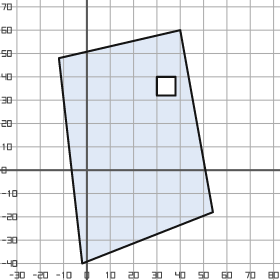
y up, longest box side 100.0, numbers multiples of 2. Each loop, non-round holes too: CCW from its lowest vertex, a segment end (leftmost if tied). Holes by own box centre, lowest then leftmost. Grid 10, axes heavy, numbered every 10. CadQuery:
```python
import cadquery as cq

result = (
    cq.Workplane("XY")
    .moveTo(-2.0, -40.0)
    .lineTo(54.0, -18.0)
    .lineTo(40.0, 60.0)
    .lineTo(-12.0, 48.0)
    .close()
    .moveTo(30.0, 32.0)
    .lineTo(38.0, 32.0)
    .lineTo(38.0, 40.0)
    .lineTo(30.0, 40.0)
    .close()
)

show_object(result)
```